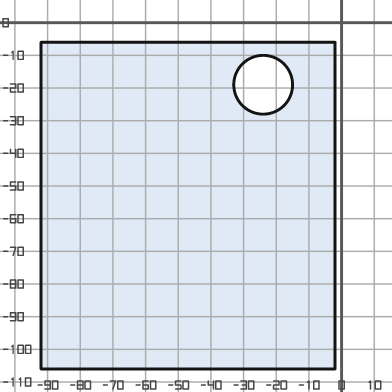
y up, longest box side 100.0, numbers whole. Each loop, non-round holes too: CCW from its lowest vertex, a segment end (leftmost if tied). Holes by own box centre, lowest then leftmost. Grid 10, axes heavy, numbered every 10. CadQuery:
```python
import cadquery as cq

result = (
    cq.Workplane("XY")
    .moveTo(-92.0, -106.0)
    .lineTo(-2.0, -106.0)
    .lineTo(-2.0, -6.0)
    .lineTo(-92.0, -6.0)
    .close()
    .moveTo(-24.0, -19.0)
    .circle(9.0)
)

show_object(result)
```